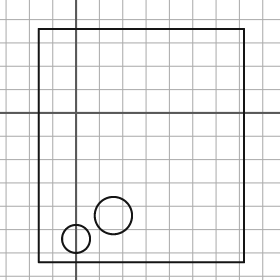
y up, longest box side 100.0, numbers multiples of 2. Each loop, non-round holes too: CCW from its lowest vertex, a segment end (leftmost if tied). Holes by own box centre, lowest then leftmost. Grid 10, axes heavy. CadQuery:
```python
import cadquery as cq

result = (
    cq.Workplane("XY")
    .moveTo(-16.0, -64.0)
    .lineTo(72.0, -64.0)
    .lineTo(72.0, 36.0)
    .lineTo(-16.0, 36.0)
    .close()
    .moveTo(0.0, -54.0)
    .circle(6.0)
    .moveTo(16.0, -44.0)
    .circle(8.0)
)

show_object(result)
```